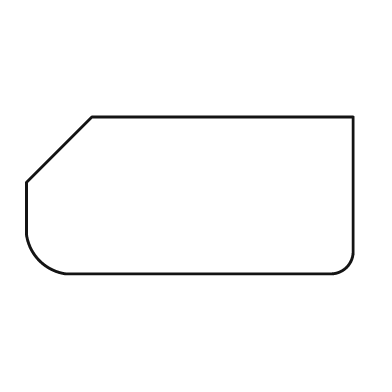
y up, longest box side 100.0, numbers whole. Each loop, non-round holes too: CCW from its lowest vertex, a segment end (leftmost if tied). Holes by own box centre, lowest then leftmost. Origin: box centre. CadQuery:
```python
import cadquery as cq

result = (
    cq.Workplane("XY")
    .moveTo(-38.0, -24.0)
    .lineTo(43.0, -24.0)
    .threePointArc((48.0, -22.0), (50.0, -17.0))
    .lineTo(50.0, 24.0)
    .lineTo(-30.0, 24.0)
    .lineTo(-50.0, 4.0)
    .lineTo(-50.0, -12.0)
    .threePointArc((-46.0, -20.0), (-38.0, -24.0))
    .close()
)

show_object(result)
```